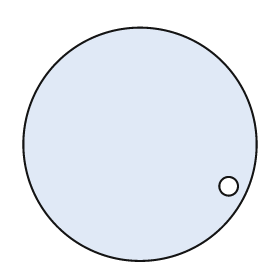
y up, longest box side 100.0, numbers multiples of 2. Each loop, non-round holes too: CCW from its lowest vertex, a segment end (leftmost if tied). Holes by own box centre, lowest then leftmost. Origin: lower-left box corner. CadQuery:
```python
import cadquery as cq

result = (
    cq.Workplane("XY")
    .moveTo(50.0, 50.0)
    .circle(50.0)
    .moveTo(88.0, 32.0)
    .circle(4.0)
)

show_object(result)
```